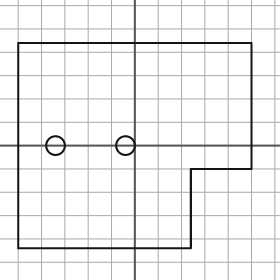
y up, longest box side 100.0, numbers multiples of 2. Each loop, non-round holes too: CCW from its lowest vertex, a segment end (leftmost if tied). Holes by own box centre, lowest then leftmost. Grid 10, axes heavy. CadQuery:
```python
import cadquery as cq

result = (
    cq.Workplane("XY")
    .moveTo(-50.0, -44.0)
    .lineTo(24.0, -44.0)
    .lineTo(24.0, -10.0)
    .lineTo(50.0, -10.0)
    .lineTo(50.0, 44.0)
    .lineTo(-50.0, 44.0)
    .close()
    .moveTo(-34.0, 0.0)
    .circle(4.0)
    .moveTo(-4.0, 0.0)
    .circle(4.0)
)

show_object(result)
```